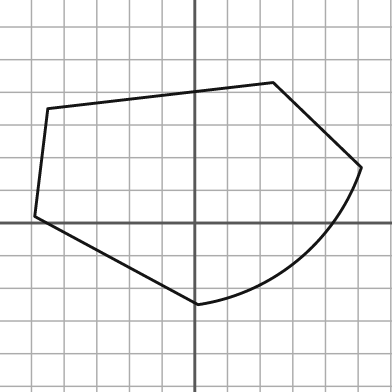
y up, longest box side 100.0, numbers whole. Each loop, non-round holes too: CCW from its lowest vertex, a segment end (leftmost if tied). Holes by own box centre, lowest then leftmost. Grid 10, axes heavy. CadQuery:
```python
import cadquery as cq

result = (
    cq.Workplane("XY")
    .moveTo(1.0, -25.0)
    .threePointArc((32.0, -11.0), (51.0, 17.0))
    .lineTo(24.0, 43.0)
    .lineTo(-45.0, 35.0)
    .lineTo(-49.0, 2.0)
    .close()
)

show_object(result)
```